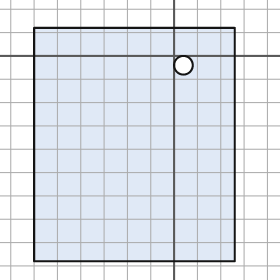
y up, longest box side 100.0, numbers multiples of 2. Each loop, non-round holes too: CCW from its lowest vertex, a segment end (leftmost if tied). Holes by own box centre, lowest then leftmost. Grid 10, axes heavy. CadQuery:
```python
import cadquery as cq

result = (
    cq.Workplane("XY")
    .moveTo(-60.0, -88.0)
    .lineTo(26.0, -88.0)
    .lineTo(26.0, 12.0)
    .lineTo(-60.0, 12.0)
    .close()
    .moveTo(4.0, -4.0)
    .circle(4.0)
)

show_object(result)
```